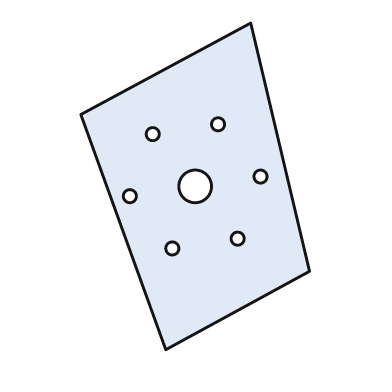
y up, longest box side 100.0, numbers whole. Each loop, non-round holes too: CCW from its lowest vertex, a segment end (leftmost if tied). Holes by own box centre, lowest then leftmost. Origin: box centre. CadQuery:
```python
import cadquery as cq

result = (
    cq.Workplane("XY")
    .moveTo(-9.0, -50.0)
    .lineTo(35.0, -26.0)
    .lineTo(17.0, 50.0)
    .lineTo(-35.0, 22.0)
    .close()
    .moveTo(-7.0, -19.0)
    .circle(2.0)
    .moveTo(13.0, -16.0)
    .circle(2.0)
    .moveTo(-20.0, -3.0)
    .circle(2.0)
    .moveTo(0.0, 0.0)
    .circle(5.0)
    .moveTo(20.0, 3.0)
    .circle(2.0)
    .moveTo(-13.0, 16.0)
    .circle(2.0)
    .moveTo(7.0, 19.0)
    .circle(2.0)
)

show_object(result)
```